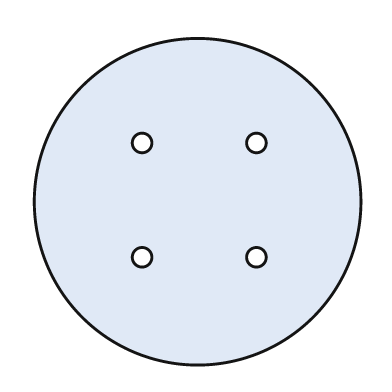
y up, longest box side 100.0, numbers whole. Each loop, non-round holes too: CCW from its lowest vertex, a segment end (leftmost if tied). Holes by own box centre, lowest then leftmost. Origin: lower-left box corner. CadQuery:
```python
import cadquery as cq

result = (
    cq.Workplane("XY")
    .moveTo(50.0, 50.0)
    .circle(50.0)
    .moveTo(33.0, 33.0)
    .circle(3.0)
    .moveTo(68.0, 33.0)
    .circle(3.0)
    .moveTo(33.0, 68.0)
    .circle(3.0)
    .moveTo(68.0, 68.0)
    .circle(3.0)
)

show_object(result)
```